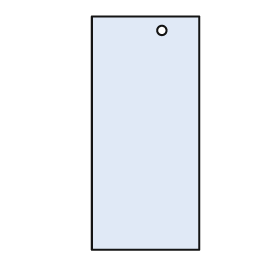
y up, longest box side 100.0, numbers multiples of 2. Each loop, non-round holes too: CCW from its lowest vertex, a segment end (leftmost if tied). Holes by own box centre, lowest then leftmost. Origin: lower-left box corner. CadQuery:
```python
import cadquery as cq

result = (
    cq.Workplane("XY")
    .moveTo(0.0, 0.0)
    .lineTo(46.0, 0.0)
    .lineTo(46.0, 100.0)
    .lineTo(0.0, 100.0)
    .close()
    .moveTo(30.0, 94.0)
    .circle(2.0)
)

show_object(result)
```